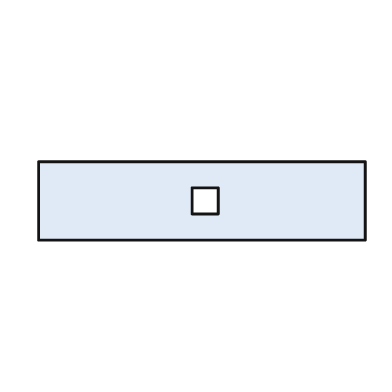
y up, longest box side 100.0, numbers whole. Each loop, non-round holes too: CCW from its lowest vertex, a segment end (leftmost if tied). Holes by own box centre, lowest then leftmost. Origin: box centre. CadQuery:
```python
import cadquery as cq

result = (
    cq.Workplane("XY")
    .moveTo(-50.0, -12.0)
    .lineTo(50.0, -12.0)
    .lineTo(50.0, 12.0)
    .lineTo(-50.0, 12.0)
    .close()
    .moveTo(-3.0, -4.0)
    .lineTo(5.0, -4.0)
    .lineTo(5.0, 4.0)
    .lineTo(-3.0, 4.0)
    .close()
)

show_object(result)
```